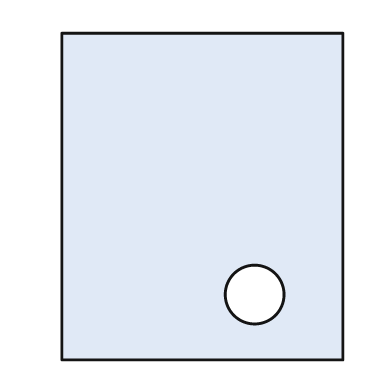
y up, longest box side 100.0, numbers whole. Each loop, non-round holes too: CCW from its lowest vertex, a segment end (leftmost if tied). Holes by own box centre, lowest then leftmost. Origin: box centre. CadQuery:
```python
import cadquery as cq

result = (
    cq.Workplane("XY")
    .moveTo(-43.0, -50.0)
    .lineTo(43.0, -50.0)
    .lineTo(43.0, 50.0)
    .lineTo(-43.0, 50.0)
    .close()
    .moveTo(16.0, -30.0)
    .circle(9.0)
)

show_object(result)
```